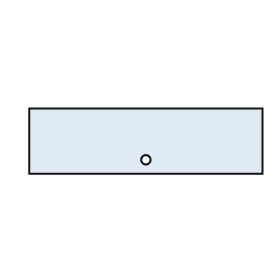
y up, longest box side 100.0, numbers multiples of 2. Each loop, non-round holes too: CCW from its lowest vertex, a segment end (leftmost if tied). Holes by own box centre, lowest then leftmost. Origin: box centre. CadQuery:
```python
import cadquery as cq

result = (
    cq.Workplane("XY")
    .moveTo(-50.0, -14.0)
    .lineTo(50.0, -14.0)
    .lineTo(50.0, 14.0)
    .lineTo(-50.0, 14.0)
    .close()
    .moveTo(0.0, -8.0)
    .circle(2.0)
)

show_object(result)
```